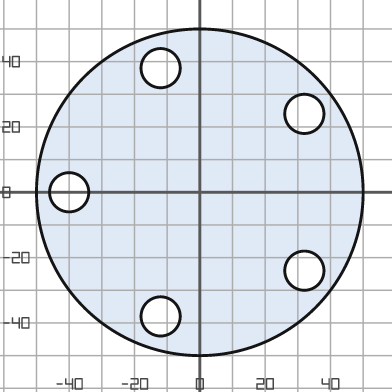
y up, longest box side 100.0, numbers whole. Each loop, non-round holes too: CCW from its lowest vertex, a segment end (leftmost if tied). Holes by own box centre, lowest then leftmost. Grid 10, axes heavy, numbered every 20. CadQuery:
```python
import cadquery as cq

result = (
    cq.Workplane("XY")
    .moveTo(0.0, 0.0)
    .circle(50.0)
    .moveTo(-12.0, -38.0)
    .circle(6.0)
    .moveTo(32.0, -24.0)
    .circle(6.0)
    .moveTo(-40.0, 0.0)
    .circle(6.0)
    .moveTo(32.0, 24.0)
    .circle(6.0)
    .moveTo(-12.0, 38.0)
    .circle(6.0)
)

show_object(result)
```